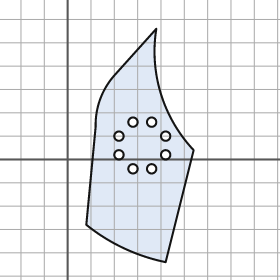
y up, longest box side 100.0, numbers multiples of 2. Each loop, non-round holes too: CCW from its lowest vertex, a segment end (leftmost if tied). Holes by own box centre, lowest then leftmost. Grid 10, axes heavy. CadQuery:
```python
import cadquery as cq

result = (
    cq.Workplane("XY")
    .moveTo(42.0, -44.0)
    .lineTo(54.0, 4.0)
    .threePointArc((40.0, 28.0), (38.0, 56.0))
    .lineTo(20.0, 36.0)
    .threePointArc((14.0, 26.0), (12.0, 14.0))
    .lineTo(8.0, -28.0)
    .threePointArc((24.0, -38.0), (42.0, -44.0))
    .close()
    .moveTo(28.0, -4.0)
    .circle(2.0)
    .moveTo(36.0, -4.0)
    .circle(2.0)
    .moveTo(22.0, 2.0)
    .circle(2.0)
    .moveTo(42.0, 2.0)
    .circle(2.0)
    .moveTo(22.0, 10.0)
    .circle(2.0)
    .moveTo(42.0, 10.0)
    .circle(2.0)
    .moveTo(28.0, 16.0)
    .circle(2.0)
    .moveTo(36.0, 16.0)
    .circle(2.0)
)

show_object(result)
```